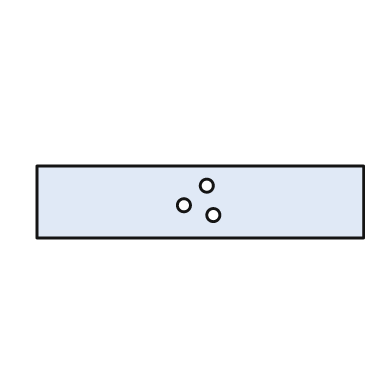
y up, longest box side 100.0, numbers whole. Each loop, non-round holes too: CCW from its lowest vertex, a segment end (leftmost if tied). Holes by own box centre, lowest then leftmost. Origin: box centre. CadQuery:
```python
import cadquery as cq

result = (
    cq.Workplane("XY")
    .moveTo(-50.0, -11.0)
    .lineTo(50.0, -11.0)
    .lineTo(50.0, 11.0)
    .lineTo(-50.0, 11.0)
    .close()
    .moveTo(4.0, -4.0)
    .circle(2.0)
    .moveTo(-5.0, -1.0)
    .circle(2.0)
    .moveTo(2.0, 5.0)
    .circle(2.0)
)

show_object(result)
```